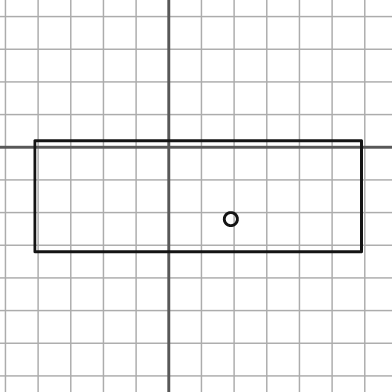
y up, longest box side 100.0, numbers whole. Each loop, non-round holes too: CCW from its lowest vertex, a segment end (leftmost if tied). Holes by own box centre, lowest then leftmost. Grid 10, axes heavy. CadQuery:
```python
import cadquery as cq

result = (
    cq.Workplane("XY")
    .moveTo(-41.0, -32.0)
    .lineTo(59.0, -32.0)
    .lineTo(59.0, 2.0)
    .lineTo(-41.0, 2.0)
    .close()
    .moveTo(19.0, -22.0)
    .circle(2.0)
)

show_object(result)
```